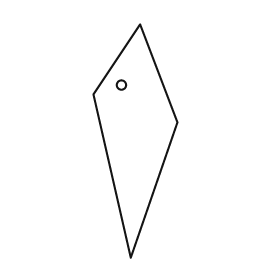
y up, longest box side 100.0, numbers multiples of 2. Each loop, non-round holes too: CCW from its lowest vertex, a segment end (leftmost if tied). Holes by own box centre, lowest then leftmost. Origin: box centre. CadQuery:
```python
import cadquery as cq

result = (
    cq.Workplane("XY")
    .moveTo(-2.0, -50.0)
    .lineTo(18.0, 8.0)
    .lineTo(2.0, 50.0)
    .lineTo(-18.0, 20.0)
    .close()
    .moveTo(-6.0, 24.0)
    .circle(2.0)
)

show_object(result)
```